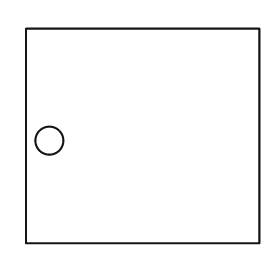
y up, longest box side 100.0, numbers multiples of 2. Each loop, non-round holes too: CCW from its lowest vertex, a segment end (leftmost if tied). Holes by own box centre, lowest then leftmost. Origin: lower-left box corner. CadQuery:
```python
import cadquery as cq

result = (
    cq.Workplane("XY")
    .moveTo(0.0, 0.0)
    .lineTo(100.0, 0.0)
    .lineTo(100.0, 92.0)
    .lineTo(0.0, 92.0)
    .close()
    .moveTo(10.0, 44.0)
    .circle(6.0)
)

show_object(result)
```